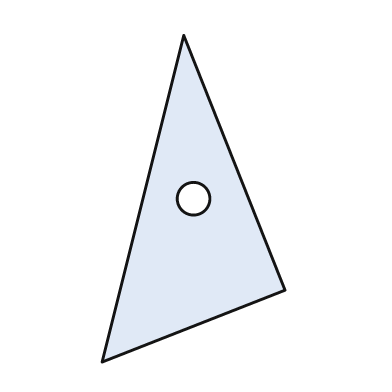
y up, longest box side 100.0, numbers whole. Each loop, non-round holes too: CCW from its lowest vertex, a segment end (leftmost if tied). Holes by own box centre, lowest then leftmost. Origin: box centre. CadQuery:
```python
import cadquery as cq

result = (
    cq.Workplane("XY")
    .moveTo(-28.0, -50.0)
    .lineTo(28.0, -28.0)
    .lineTo(-3.0, 50.0)
    .close()
    .moveTo(0.0, 0.0)
    .circle(5.0)
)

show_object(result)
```